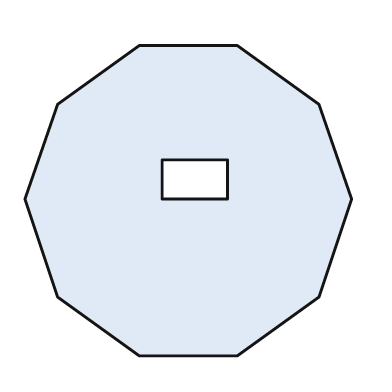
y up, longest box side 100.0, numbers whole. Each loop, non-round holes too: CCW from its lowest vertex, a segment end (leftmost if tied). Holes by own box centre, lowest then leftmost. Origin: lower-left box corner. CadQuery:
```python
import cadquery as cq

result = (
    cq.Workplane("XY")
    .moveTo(35.0, 0.0)
    .lineTo(65.0, 0.0)
    .lineTo(90.0, 18.0)
    .lineTo(100.0, 48.0)
    .lineTo(90.0, 77.0)
    .lineTo(65.0, 95.0)
    .lineTo(35.0, 95.0)
    .lineTo(10.0, 77.0)
    .lineTo(0.0, 48.0)
    .lineTo(10.0, 18.0)
    .close()
    .moveTo(42.0, 48.0)
    .lineTo(62.0, 48.0)
    .lineTo(62.0, 60.0)
    .lineTo(42.0, 60.0)
    .close()
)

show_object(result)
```